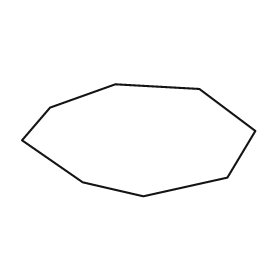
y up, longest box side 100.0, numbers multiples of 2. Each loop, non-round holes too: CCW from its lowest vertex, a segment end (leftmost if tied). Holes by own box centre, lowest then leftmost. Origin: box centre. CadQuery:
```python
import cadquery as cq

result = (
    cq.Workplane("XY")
    .moveTo(2.0, -24.0)
    .lineTo(38.0, -16.0)
    .lineTo(50.0, 4.0)
    .lineTo(26.0, 22.0)
    .lineTo(-10.0, 24.0)
    .lineTo(-38.0, 14.0)
    .lineTo(-50.0, 0.0)
    .lineTo(-24.0, -18.0)
    .close()
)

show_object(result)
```